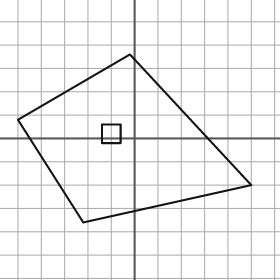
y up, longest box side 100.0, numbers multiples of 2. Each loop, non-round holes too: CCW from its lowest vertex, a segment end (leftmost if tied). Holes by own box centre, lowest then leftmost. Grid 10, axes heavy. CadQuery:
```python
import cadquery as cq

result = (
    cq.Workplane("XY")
    .moveTo(-22.0, -36.0)
    .lineTo(50.0, -20.0)
    .lineTo(-2.0, 36.0)
    .lineTo(-50.0, 8.0)
    .close()
    .moveTo(-14.0, -2.0)
    .lineTo(-6.0, -2.0)
    .lineTo(-6.0, 6.0)
    .lineTo(-14.0, 6.0)
    .close()
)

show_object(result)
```